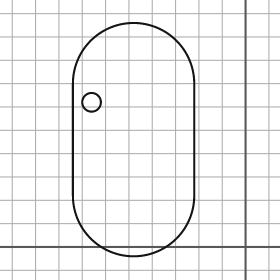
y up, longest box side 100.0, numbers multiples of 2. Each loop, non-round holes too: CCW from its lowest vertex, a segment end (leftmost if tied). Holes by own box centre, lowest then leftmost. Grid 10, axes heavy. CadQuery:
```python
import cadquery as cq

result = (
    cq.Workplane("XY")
    .moveTo(-74.0, 22.0)
    .threePointArc((-48.0, -4.0), (-22.0, 22.0))
    .lineTo(-22.0, 70.0)
    .threePointArc((-48.0, 96.0), (-74.0, 70.0))
    .close()
    .moveTo(-66.0, 62.0)
    .circle(4.0)
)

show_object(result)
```